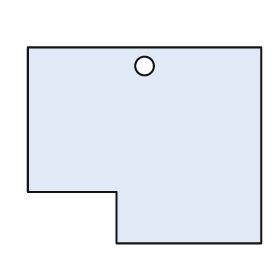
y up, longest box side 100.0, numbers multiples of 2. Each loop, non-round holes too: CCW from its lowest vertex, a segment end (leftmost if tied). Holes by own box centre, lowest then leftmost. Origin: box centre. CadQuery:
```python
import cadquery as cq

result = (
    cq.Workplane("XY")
    .moveTo(-12.0, -42.0)
    .lineTo(50.0, -42.0)
    .lineTo(50.0, 42.0)
    .lineTo(-50.0, 42.0)
    .lineTo(-50.0, -20.0)
    .lineTo(-12.0, -20.0)
    .close()
    .moveTo(0.0, 34.0)
    .circle(4.0)
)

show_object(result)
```